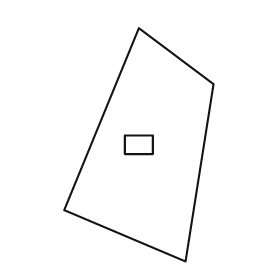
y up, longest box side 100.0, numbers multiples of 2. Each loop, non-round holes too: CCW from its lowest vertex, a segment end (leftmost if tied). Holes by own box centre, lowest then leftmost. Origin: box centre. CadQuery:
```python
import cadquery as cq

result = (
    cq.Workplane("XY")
    .moveTo(20.0, -50.0)
    .lineTo(32.0, 26.0)
    .lineTo(0.0, 50.0)
    .lineTo(-32.0, -28.0)
    .close()
    .moveTo(-6.0, -4.0)
    .lineTo(6.0, -4.0)
    .lineTo(6.0, 4.0)
    .lineTo(-6.0, 4.0)
    .close()
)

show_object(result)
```